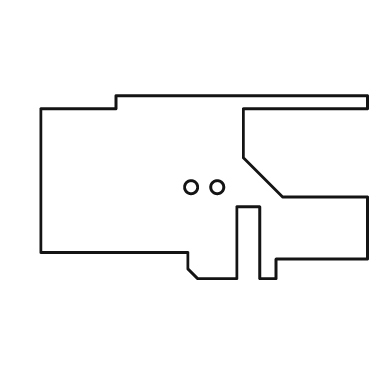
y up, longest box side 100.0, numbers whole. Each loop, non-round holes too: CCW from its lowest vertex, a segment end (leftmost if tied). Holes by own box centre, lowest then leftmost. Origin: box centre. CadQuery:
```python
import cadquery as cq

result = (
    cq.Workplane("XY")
    .moveTo(-2.0, -28.0)
    .lineTo(10.0, -28.0)
    .lineTo(10.0, -6.0)
    .lineTo(17.0, -6.0)
    .lineTo(17.0, -28.0)
    .lineTo(22.0, -28.0)
    .lineTo(22.0, -22.0)
    .lineTo(50.0, -22.0)
    .lineTo(50.0, -3.0)
    .lineTo(24.0, -3.0)
    .lineTo(12.0, 9.0)
    .lineTo(12.0, 24.0)
    .lineTo(50.0, 24.0)
    .lineTo(50.0, 28.0)
    .lineTo(-27.0, 28.0)
    .lineTo(-27.0, 24.0)
    .lineTo(-50.0, 24.0)
    .lineTo(-50.0, -20.0)
    .lineTo(-5.0, -20.0)
    .lineTo(-5.0, -25.0)
    .close()
    .moveTo(-4.0, 0.0)
    .circle(2.0)
    .moveTo(4.0, 0.0)
    .circle(2.0)
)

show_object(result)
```